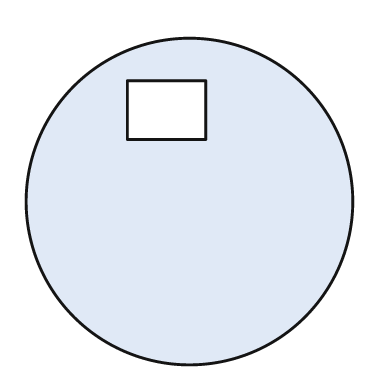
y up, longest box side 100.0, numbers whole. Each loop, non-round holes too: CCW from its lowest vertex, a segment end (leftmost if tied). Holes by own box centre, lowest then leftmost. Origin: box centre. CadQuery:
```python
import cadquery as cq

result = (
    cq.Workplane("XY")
    .moveTo(0.0, 0.0)
    .circle(50.0)
    .moveTo(-19.0, 19.0)
    .lineTo(5.0, 19.0)
    .lineTo(5.0, 37.0)
    .lineTo(-19.0, 37.0)
    .close()
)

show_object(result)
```